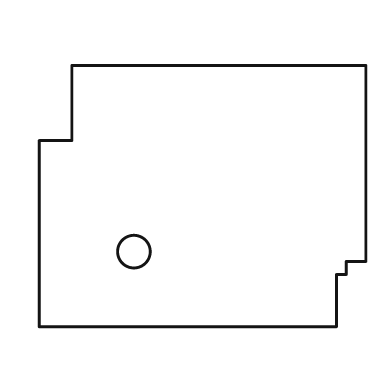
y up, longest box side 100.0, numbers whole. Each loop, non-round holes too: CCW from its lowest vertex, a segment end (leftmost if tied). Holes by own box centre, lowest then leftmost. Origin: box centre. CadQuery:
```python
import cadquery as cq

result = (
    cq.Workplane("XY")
    .moveTo(-50.0, -40.0)
    .lineTo(41.0, -40.0)
    .lineTo(41.0, -24.0)
    .lineTo(44.0, -24.0)
    .lineTo(44.0, -20.0)
    .lineTo(50.0, -20.0)
    .lineTo(50.0, 40.0)
    .lineTo(-40.0, 40.0)
    .lineTo(-40.0, 17.0)
    .lineTo(-50.0, 17.0)
    .close()
    .moveTo(-21.0, -17.0)
    .circle(5.0)
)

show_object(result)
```